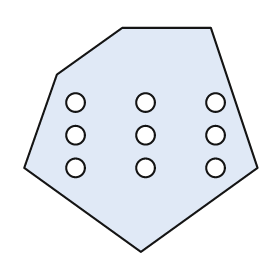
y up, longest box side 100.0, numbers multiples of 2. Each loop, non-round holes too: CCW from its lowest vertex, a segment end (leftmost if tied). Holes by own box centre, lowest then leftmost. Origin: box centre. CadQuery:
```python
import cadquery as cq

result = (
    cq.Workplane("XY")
    .moveTo(0.0, -48.0)
    .lineTo(50.0, -12.0)
    .lineTo(30.0, 48.0)
    .lineTo(-8.0, 48.0)
    .lineTo(-36.0, 28.0)
    .lineTo(-50.0, -12.0)
    .close()
    .moveTo(-28.0, -12.0)
    .circle(4.0)
    .moveTo(2.0, -12.0)
    .circle(4.0)
    .moveTo(32.0, -12.0)
    .circle(4.0)
    .moveTo(-28.0, 2.0)
    .circle(4.0)
    .moveTo(2.0, 2.0)
    .circle(4.0)
    .moveTo(32.0, 2.0)
    .circle(4.0)
    .moveTo(-28.0, 16.0)
    .circle(4.0)
    .moveTo(2.0, 16.0)
    .circle(4.0)
    .moveTo(32.0, 16.0)
    .circle(4.0)
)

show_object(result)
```